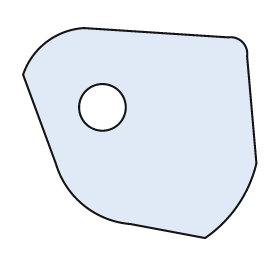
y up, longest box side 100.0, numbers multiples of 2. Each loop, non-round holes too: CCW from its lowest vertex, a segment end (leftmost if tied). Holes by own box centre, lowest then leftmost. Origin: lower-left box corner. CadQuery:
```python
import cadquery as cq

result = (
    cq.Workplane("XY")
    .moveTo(78.0, 0.0)
    .threePointArc((92.0, 14.0), (100.0, 32.0))
    .lineTo(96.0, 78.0)
    .threePointArc((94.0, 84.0), (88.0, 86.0))
    .lineTo(26.0, 90.0)
    .threePointArc((10.0, 84.0), (0.0, 70.0))
    .lineTo(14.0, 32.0)
    .threePointArc((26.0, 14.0), (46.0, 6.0))
    .close()
    .moveTo(34.0, 56.0)
    .circle(10.0)
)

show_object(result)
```